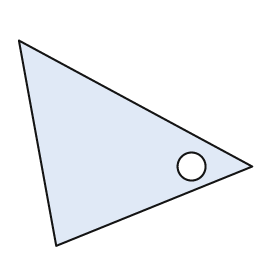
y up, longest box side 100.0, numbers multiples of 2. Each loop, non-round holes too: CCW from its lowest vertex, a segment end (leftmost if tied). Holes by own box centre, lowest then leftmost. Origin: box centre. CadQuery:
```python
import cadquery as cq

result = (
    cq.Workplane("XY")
    .moveTo(-34.0, -44.0)
    .lineTo(50.0, -10.0)
    .lineTo(-50.0, 44.0)
    .close()
    .moveTo(24.0, -10.0)
    .circle(6.0)
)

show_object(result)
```